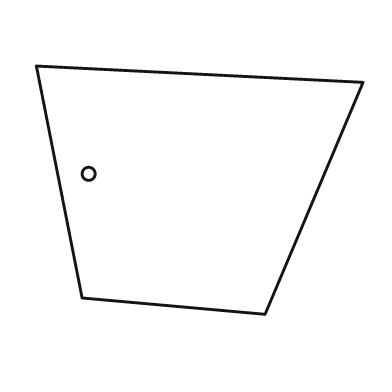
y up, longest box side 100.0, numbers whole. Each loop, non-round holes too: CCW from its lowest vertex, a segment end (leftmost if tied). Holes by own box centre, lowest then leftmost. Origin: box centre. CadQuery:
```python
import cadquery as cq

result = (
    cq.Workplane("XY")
    .moveTo(20.0, -38.0)
    .lineTo(50.0, 33.0)
    .lineTo(-50.0, 38.0)
    .lineTo(-36.0, -33.0)
    .close()
    .moveTo(-34.0, 5.0)
    .circle(2.0)
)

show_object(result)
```